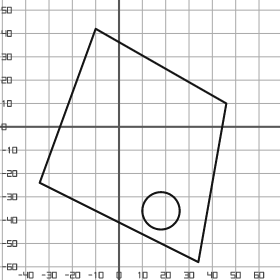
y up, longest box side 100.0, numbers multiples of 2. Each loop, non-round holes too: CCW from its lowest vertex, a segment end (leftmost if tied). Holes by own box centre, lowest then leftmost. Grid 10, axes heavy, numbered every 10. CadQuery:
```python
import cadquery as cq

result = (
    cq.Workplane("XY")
    .moveTo(34.0, -58.0)
    .lineTo(46.0, 10.0)
    .lineTo(-10.0, 42.0)
    .lineTo(-34.0, -24.0)
    .close()
    .moveTo(18.0, -36.0)
    .circle(8.0)
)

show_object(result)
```